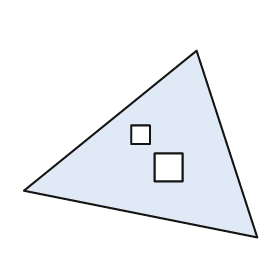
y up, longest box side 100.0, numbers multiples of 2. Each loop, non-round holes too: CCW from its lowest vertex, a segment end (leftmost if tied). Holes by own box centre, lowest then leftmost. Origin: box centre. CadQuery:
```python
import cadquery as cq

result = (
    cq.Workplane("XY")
    .moveTo(50.0, -40.0)
    .lineTo(24.0, 40.0)
    .lineTo(-50.0, -20.0)
    .close()
    .moveTo(6.0, -16.0)
    .lineTo(18.0, -16.0)
    .lineTo(18.0, -4.0)
    .lineTo(6.0, -4.0)
    .close()
    .moveTo(-4.0, 0.0)
    .lineTo(4.0, 0.0)
    .lineTo(4.0, 8.0)
    .lineTo(-4.0, 8.0)
    .close()
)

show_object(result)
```